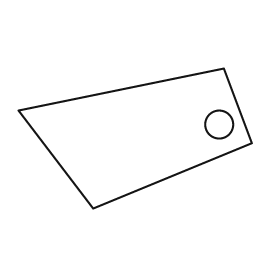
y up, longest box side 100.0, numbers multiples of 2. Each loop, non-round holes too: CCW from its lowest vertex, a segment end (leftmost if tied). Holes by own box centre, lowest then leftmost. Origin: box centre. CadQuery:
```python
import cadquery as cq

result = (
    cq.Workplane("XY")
    .moveTo(-18.0, -30.0)
    .lineTo(50.0, -2.0)
    .lineTo(38.0, 30.0)
    .lineTo(-50.0, 12.0)
    .close()
    .moveTo(36.0, 6.0)
    .circle(6.0)
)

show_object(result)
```